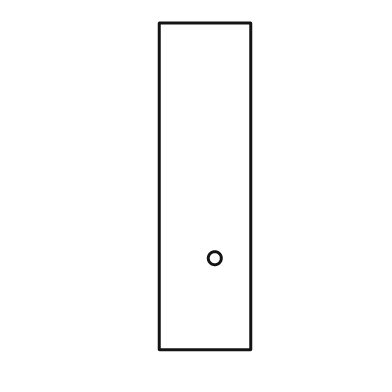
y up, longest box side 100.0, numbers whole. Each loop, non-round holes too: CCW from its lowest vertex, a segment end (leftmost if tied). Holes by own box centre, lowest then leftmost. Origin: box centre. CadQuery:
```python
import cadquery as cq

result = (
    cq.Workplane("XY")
    .moveTo(-14.0, -50.0)
    .lineTo(14.0, -50.0)
    .lineTo(14.0, 50.0)
    .lineTo(-14.0, 50.0)
    .close()
    .moveTo(3.0, -22.0)
    .circle(2.0)
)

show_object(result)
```